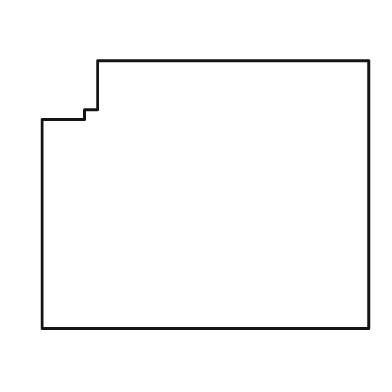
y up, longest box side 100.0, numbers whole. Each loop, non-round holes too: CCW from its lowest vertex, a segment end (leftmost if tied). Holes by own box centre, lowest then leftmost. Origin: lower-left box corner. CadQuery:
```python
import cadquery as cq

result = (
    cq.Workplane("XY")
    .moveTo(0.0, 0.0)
    .lineTo(100.0, 0.0)
    .lineTo(100.0, 82.0)
    .lineTo(17.0, 82.0)
    .lineTo(17.0, 67.0)
    .lineTo(13.0, 67.0)
    .lineTo(13.0, 64.0)
    .lineTo(0.0, 64.0)
    .close()
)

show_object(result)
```